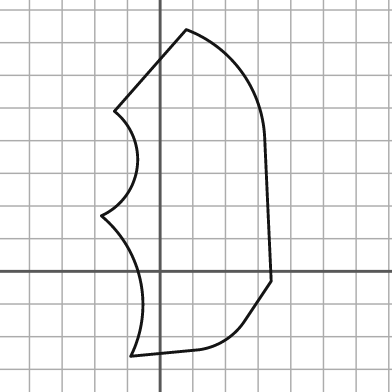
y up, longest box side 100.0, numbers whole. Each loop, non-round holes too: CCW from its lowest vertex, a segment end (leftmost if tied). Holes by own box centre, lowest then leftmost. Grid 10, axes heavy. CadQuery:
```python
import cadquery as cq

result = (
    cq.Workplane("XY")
    .moveTo(-9.0, -26.0)
    .lineTo(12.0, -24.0)
    .threePointArc((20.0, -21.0), (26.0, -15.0))
    .lineTo(34.0, -3.0)
    .lineTo(32.0, 41.0)
    .threePointArc((25.0, 61.0), (8.0, 74.0))
    .lineTo(-14.0, 49.0)
    .threePointArc((-7.0, 32.0), (-18.0, 17.0))
    .threePointArc((-6.0, -3.0), (-9.0, -26.0))
    .close()
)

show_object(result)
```